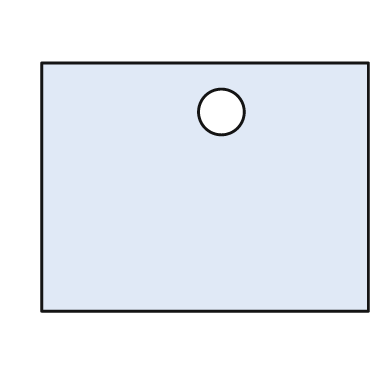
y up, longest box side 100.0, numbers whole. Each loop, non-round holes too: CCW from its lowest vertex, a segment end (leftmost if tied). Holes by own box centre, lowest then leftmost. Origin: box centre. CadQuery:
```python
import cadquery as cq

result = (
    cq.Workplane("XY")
    .moveTo(-50.0, -38.0)
    .lineTo(50.0, -38.0)
    .lineTo(50.0, 38.0)
    .lineTo(-50.0, 38.0)
    .close()
    .moveTo(5.0, 23.0)
    .circle(7.0)
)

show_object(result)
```